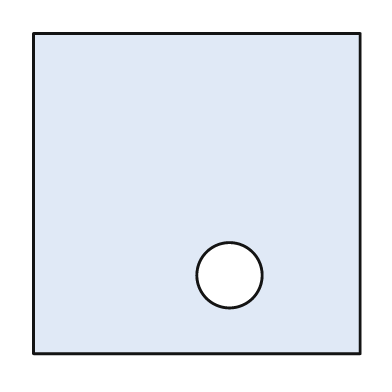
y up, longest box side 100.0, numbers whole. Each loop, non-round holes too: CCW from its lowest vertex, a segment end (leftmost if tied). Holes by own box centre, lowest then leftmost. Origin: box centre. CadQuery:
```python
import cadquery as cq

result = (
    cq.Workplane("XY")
    .moveTo(-50.0, -49.0)
    .lineTo(50.0, -49.0)
    .lineTo(50.0, 49.0)
    .lineTo(-50.0, 49.0)
    .close()
    .moveTo(10.0, -25.0)
    .circle(10.0)
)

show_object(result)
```